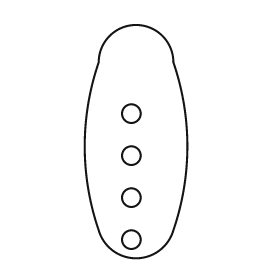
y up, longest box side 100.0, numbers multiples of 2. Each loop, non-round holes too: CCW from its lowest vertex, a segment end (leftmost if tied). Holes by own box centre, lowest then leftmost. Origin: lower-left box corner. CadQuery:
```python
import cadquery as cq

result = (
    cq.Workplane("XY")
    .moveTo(6.0, 12.0)
    .threePointArc((22.0, 0.0), (38.0, 12.0))
    .threePointArc((44.0, 48.0), (38.0, 84.0))
    .threePointArc((22.0, 100.0), (6.0, 84.0))
    .threePointArc((0.0, 48.0), (6.0, 12.0))
    .close()
    .moveTo(20.0, 8.0)
    .circle(4.0)
    .moveTo(20.0, 26.0)
    .circle(4.0)
    .moveTo(20.0, 44.0)
    .circle(4.0)
    .moveTo(20.0, 62.0)
    .circle(4.0)
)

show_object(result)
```